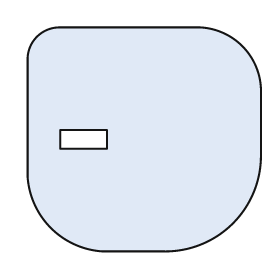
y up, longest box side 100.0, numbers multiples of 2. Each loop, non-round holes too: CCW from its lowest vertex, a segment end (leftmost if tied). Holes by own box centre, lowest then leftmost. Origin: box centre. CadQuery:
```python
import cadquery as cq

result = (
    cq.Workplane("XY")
    .moveTo(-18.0, -48.0)
    .lineTo(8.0, -48.0)
    .threePointArc((38.0, -36.0), (50.0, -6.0))
    .lineTo(50.0, 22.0)
    .threePointArc((42.0, 40.0), (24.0, 48.0))
    .lineTo(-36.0, 48.0)
    .threePointArc((-46.0, 44.0), (-50.0, 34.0))
    .lineTo(-50.0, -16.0)
    .threePointArc((-40.0, -38.0), (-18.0, -48.0))
    .close()
    .moveTo(-36.0, -4.0)
    .lineTo(-16.0, -4.0)
    .lineTo(-16.0, 4.0)
    .lineTo(-36.0, 4.0)
    .close()
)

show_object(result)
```